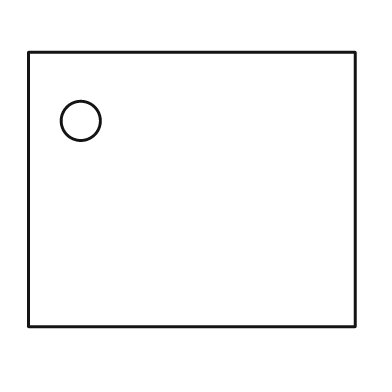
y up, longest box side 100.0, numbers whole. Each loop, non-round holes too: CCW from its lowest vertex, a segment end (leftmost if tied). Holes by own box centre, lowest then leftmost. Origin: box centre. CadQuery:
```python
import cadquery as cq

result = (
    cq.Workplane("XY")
    .moveTo(-50.0, -42.0)
    .lineTo(50.0, -42.0)
    .lineTo(50.0, 42.0)
    .lineTo(-50.0, 42.0)
    .close()
    .moveTo(-34.0, 21.0)
    .circle(6.0)
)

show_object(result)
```